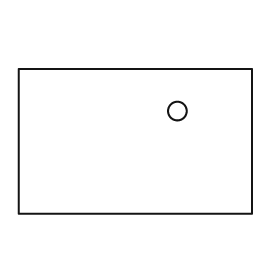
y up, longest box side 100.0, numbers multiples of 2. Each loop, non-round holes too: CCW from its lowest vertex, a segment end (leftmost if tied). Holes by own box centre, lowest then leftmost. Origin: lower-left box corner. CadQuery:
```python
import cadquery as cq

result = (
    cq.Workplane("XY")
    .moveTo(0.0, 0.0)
    .lineTo(100.0, 0.0)
    .lineTo(100.0, 62.0)
    .lineTo(0.0, 62.0)
    .close()
    .moveTo(68.0, 44.0)
    .circle(4.0)
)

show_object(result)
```